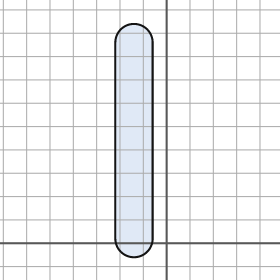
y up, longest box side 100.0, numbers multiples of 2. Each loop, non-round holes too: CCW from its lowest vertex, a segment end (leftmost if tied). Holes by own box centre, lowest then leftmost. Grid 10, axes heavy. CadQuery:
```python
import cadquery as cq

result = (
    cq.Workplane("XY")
    .moveTo(-22.0, 2.0)
    .threePointArc((-14.0, -6.0), (-6.0, 2.0))
    .lineTo(-6.0, 86.0)
    .threePointArc((-14.0, 94.0), (-22.0, 86.0))
    .close()
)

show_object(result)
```